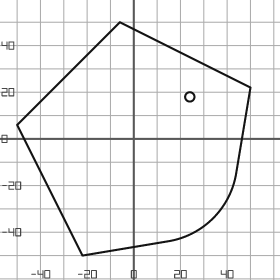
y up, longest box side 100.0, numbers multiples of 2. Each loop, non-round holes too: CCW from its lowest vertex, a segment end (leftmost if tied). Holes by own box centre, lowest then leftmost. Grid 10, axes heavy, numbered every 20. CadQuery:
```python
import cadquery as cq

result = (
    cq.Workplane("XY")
    .moveTo(-22.0, -50.0)
    .lineTo(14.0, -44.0)
    .threePointArc((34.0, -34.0), (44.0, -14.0))
    .lineTo(50.0, 22.0)
    .lineTo(-6.0, 50.0)
    .lineTo(-50.0, 6.0)
    .close()
    .moveTo(24.0, 18.0)
    .circle(2.0)
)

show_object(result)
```